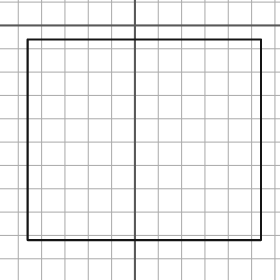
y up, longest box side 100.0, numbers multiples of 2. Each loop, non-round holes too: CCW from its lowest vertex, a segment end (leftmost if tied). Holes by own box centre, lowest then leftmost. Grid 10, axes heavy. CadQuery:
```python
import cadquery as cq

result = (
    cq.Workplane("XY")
    .moveTo(-46.0, -92.0)
    .lineTo(54.0, -92.0)
    .lineTo(54.0, -6.0)
    .lineTo(-46.0, -6.0)
    .close()
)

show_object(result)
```